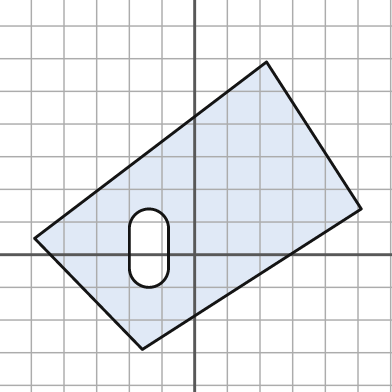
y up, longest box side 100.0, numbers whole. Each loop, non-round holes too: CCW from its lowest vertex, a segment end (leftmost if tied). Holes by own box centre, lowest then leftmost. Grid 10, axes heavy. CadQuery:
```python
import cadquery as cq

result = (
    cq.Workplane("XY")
    .moveTo(-16.0, -29.0)
    .lineTo(51.0, 14.0)
    .lineTo(22.0, 59.0)
    .lineTo(-49.0, 5.0)
    .close()
    .moveTo(-20.0, -4.0)
    .threePointArc((-14.0, -10.0), (-8.0, -4.0))
    .lineTo(-8.0, 8.0)
    .threePointArc((-14.0, 14.0), (-20.0, 8.0))
    .close()
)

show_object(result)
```